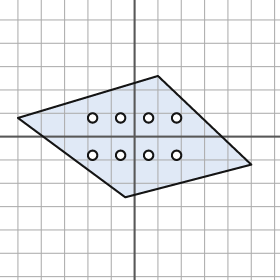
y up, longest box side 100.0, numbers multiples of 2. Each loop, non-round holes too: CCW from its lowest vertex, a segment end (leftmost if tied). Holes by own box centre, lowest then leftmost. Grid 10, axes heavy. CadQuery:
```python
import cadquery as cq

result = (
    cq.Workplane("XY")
    .moveTo(-4.0, -26.0)
    .lineTo(50.0, -12.0)
    .lineTo(10.0, 26.0)
    .lineTo(-50.0, 8.0)
    .close()
    .moveTo(-18.0, -8.0)
    .circle(2.0)
    .moveTo(-6.0, -8.0)
    .circle(2.0)
    .moveTo(6.0, -8.0)
    .circle(2.0)
    .moveTo(18.0, -8.0)
    .circle(2.0)
    .moveTo(-18.0, 8.0)
    .circle(2.0)
    .moveTo(-6.0, 8.0)
    .circle(2.0)
    .moveTo(6.0, 8.0)
    .circle(2.0)
    .moveTo(18.0, 8.0)
    .circle(2.0)
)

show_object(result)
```